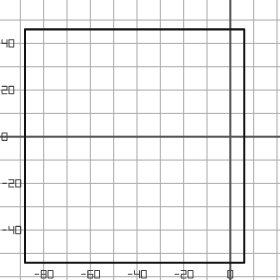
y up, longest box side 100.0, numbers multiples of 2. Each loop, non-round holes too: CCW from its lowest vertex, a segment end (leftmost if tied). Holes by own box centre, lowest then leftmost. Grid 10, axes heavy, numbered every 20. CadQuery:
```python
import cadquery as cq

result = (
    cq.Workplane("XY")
    .moveTo(-88.0, -54.0)
    .lineTo(6.0, -54.0)
    .lineTo(6.0, 46.0)
    .lineTo(-88.0, 46.0)
    .close()
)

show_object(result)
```